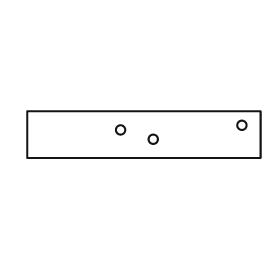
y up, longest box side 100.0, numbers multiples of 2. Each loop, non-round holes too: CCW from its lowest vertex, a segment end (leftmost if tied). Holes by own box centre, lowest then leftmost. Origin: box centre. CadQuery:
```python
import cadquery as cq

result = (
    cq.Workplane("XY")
    .moveTo(-50.0, -10.0)
    .lineTo(50.0, -10.0)
    .lineTo(50.0, 10.0)
    .lineTo(-50.0, 10.0)
    .close()
    .moveTo(4.0, -2.0)
    .circle(2.0)
    .moveTo(-10.0, 2.0)
    .circle(2.0)
    .moveTo(42.0, 4.0)
    .circle(2.0)
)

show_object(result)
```